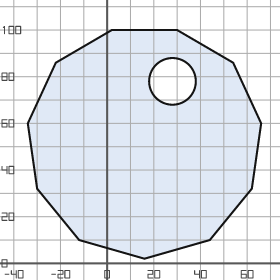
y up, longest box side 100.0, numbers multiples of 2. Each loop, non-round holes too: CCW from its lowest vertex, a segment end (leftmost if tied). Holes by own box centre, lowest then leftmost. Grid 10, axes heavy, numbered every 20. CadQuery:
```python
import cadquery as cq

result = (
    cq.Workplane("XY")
    .moveTo(16.0, 2.0)
    .lineTo(44.0, 10.0)
    .lineTo(62.0, 32.0)
    .lineTo(66.0, 60.0)
    .lineTo(54.0, 86.0)
    .lineTo(30.0, 100.0)
    .lineTo(2.0, 100.0)
    .lineTo(-22.0, 86.0)
    .lineTo(-34.0, 60.0)
    .lineTo(-30.0, 32.0)
    .lineTo(-12.0, 10.0)
    .close()
    .moveTo(28.0, 78.0)
    .circle(10.0)
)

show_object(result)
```